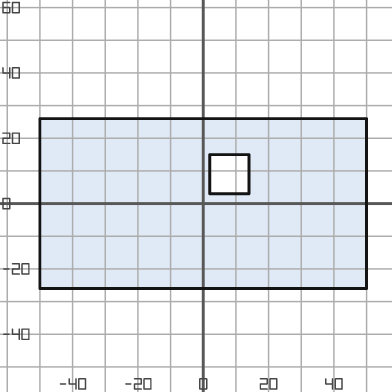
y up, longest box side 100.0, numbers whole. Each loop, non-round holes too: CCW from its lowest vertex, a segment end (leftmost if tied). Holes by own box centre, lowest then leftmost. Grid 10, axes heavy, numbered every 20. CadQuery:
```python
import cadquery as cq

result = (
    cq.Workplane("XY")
    .moveTo(-50.0, -26.0)
    .lineTo(50.0, -26.0)
    .lineTo(50.0, 26.0)
    .lineTo(-50.0, 26.0)
    .close()
    .moveTo(2.0, 3.0)
    .lineTo(14.0, 3.0)
    .lineTo(14.0, 15.0)
    .lineTo(2.0, 15.0)
    .close()
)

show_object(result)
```